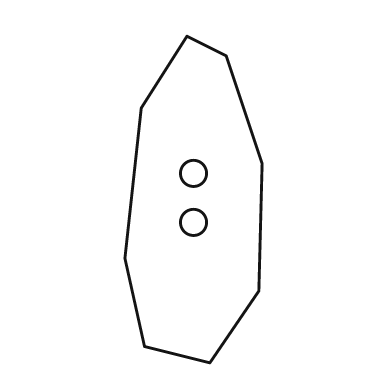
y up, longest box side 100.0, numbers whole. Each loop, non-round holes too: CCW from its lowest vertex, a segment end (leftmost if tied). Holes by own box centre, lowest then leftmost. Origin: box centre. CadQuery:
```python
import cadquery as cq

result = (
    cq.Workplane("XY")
    .moveTo(5.0, -50.0)
    .lineTo(20.0, -28.0)
    .lineTo(21.0, 11.0)
    .lineTo(10.0, 44.0)
    .lineTo(-2.0, 50.0)
    .lineTo(-16.0, 28.0)
    .lineTo(-21.0, -18.0)
    .lineTo(-15.0, -45.0)
    .close()
    .moveTo(0.0, -7.0)
    .circle(4.0)
    .moveTo(0.0, 8.0)
    .circle(4.0)
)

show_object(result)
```